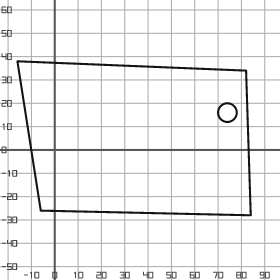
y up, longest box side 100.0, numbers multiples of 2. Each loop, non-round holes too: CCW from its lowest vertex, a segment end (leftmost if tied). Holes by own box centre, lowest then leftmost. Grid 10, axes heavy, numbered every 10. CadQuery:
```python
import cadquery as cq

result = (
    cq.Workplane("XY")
    .moveTo(84.0, -28.0)
    .lineTo(82.0, 34.0)
    .lineTo(-16.0, 38.0)
    .lineTo(-6.0, -26.0)
    .close()
    .moveTo(74.0, 16.0)
    .circle(4.0)
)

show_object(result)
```